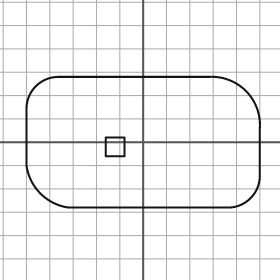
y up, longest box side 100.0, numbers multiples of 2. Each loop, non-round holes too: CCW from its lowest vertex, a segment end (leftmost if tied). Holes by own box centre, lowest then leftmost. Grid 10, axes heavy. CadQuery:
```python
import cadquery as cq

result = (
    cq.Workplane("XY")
    .moveTo(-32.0, -28.0)
    .lineTo(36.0, -28.0)
    .threePointArc((46.0, -24.0), (50.0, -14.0))
    .lineTo(50.0, 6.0)
    .threePointArc((44.0, 22.0), (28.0, 28.0))
    .lineTo(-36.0, 28.0)
    .threePointArc((-46.0, 24.0), (-50.0, 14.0))
    .lineTo(-50.0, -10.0)
    .threePointArc((-44.0, -22.0), (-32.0, -28.0))
    .close()
    .moveTo(-16.0, -6.0)
    .lineTo(-8.0, -6.0)
    .lineTo(-8.0, 2.0)
    .lineTo(-16.0, 2.0)
    .close()
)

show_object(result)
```